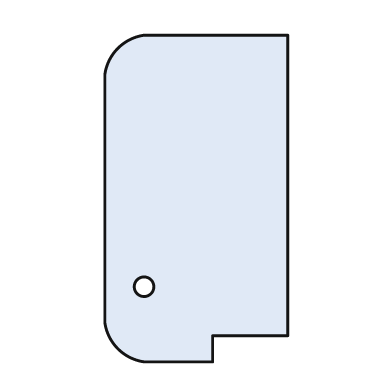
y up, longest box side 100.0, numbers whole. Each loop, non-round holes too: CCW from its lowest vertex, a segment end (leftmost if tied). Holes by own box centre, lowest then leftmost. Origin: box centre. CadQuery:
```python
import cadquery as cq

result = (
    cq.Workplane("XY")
    .moveTo(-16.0, -50.0)
    .lineTo(5.0, -50.0)
    .lineTo(5.0, -42.0)
    .lineTo(28.0, -42.0)
    .lineTo(28.0, 50.0)
    .lineTo(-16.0, 50.0)
    .threePointArc((-24.0, 46.0), (-28.0, 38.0))
    .lineTo(-28.0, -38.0)
    .threePointArc((-24.0, -46.0), (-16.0, -50.0))
    .close()
    .moveTo(-16.0, -27.0)
    .circle(3.0)
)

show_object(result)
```